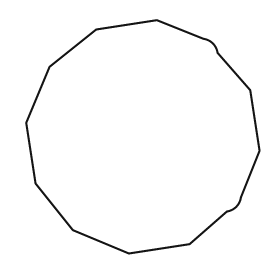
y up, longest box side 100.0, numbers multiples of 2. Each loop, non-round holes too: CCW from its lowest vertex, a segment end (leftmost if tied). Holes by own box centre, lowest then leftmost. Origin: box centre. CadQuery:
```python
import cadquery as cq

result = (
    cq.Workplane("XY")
    .moveTo(-6.0, -50.0)
    .lineTo(20.0, -46.0)
    .lineTo(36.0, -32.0)
    .threePointArc((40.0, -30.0), (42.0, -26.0))
    .lineTo(50.0, -6.0)
    .lineTo(46.0, 20.0)
    .lineTo(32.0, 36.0)
    .threePointArc((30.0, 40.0), (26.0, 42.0))
    .lineTo(6.0, 50.0)
    .lineTo(-20.0, 46.0)
    .lineTo(-40.0, 30.0)
    .lineTo(-50.0, 6.0)
    .lineTo(-46.0, -20.0)
    .lineTo(-30.0, -40.0)
    .close()
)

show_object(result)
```